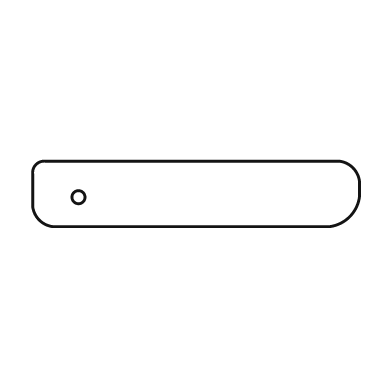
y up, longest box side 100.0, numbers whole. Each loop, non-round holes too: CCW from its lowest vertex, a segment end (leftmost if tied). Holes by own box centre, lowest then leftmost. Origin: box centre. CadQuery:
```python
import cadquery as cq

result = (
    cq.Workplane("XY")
    .moveTo(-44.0, -10.0)
    .lineTo(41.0, -10.0)
    .threePointArc((47.0, -7.0), (50.0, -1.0))
    .lineTo(50.0, 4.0)
    .threePointArc((48.0, 8.0), (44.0, 10.0))
    .lineTo(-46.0, 10.0)
    .threePointArc((-49.0, 9.0), (-50.0, 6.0))
    .lineTo(-50.0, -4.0)
    .threePointArc((-48.0, -8.0), (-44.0, -10.0))
    .close()
    .moveTo(-36.0, -1.0)
    .circle(2.0)
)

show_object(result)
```